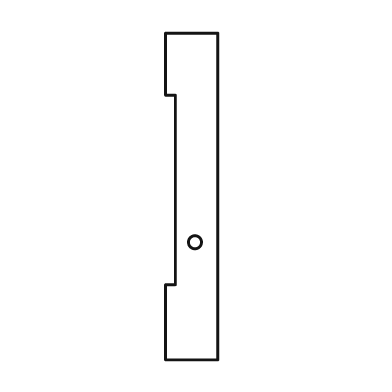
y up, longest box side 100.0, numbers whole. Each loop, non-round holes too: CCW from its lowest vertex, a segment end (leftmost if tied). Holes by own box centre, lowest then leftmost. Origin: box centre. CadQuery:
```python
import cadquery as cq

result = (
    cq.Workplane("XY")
    .moveTo(-8.0, -50.0)
    .lineTo(8.0, -50.0)
    .lineTo(8.0, 50.0)
    .lineTo(-8.0, 50.0)
    .lineTo(-8.0, 31.0)
    .lineTo(-5.0, 31.0)
    .lineTo(-5.0, -27.0)
    .lineTo(-8.0, -27.0)
    .close()
    .moveTo(1.0, -14.0)
    .circle(2.0)
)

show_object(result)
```